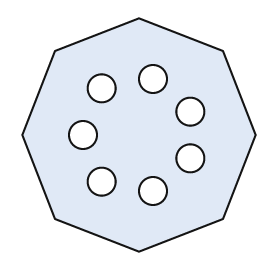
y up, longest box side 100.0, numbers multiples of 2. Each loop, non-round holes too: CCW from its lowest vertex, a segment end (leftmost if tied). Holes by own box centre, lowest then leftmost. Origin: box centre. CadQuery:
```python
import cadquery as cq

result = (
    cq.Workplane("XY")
    .moveTo(0.0, -50.0)
    .lineTo(36.0, -36.0)
    .lineTo(50.0, 0.0)
    .lineTo(36.0, 36.0)
    .lineTo(0.0, 50.0)
    .lineTo(-36.0, 36.0)
    .lineTo(-50.0, 0.0)
    .lineTo(-36.0, -36.0)
    .close()
    .moveTo(6.0, -24.0)
    .circle(6.0)
    .moveTo(-16.0, -20.0)
    .circle(6.0)
    .moveTo(22.0, -10.0)
    .circle(6.0)
    .moveTo(-24.0, 0.0)
    .circle(6.0)
    .moveTo(22.0, 10.0)
    .circle(6.0)
    .moveTo(-16.0, 20.0)
    .circle(6.0)
    .moveTo(6.0, 24.0)
    .circle(6.0)
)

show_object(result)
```